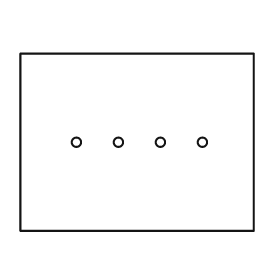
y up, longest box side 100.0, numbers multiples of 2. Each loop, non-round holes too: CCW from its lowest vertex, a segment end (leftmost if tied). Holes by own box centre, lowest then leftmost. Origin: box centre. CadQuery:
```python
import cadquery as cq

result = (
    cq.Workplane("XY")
    .moveTo(-50.0, -38.0)
    .lineTo(50.0, -38.0)
    .lineTo(50.0, 38.0)
    .lineTo(-50.0, 38.0)
    .close()
    .moveTo(-26.0, 0.0)
    .circle(2.0)
    .moveTo(-8.0, 0.0)
    .circle(2.0)
    .moveTo(10.0, 0.0)
    .circle(2.0)
    .moveTo(28.0, 0.0)
    .circle(2.0)
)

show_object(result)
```